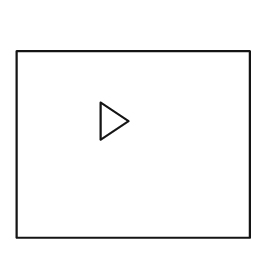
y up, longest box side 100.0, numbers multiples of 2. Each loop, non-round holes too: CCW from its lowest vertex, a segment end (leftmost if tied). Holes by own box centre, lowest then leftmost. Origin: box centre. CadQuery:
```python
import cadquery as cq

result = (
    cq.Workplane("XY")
    .moveTo(-50.0, -40.0)
    .lineTo(50.0, -40.0)
    .lineTo(50.0, 40.0)
    .lineTo(-50.0, 40.0)
    .close()
    .moveTo(-14.0, 2.0)
    .lineTo(-2.0, 10.0)
    .lineTo(-14.0, 18.0)
    .close()
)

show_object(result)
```